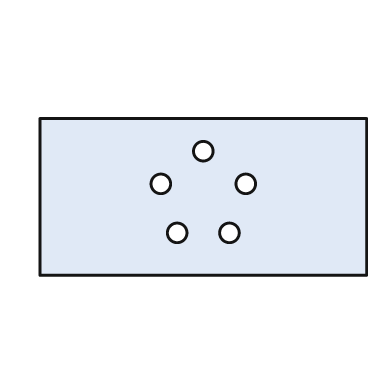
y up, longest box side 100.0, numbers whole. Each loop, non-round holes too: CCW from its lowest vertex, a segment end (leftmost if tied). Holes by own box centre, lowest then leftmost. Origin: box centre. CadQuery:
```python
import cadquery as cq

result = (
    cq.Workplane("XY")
    .moveTo(-50.0, -24.0)
    .lineTo(50.0, -24.0)
    .lineTo(50.0, 24.0)
    .lineTo(-50.0, 24.0)
    .close()
    .moveTo(-8.0, -11.0)
    .circle(3.0)
    .moveTo(8.0, -11.0)
    .circle(3.0)
    .moveTo(-13.0, 4.0)
    .circle(3.0)
    .moveTo(13.0, 4.0)
    .circle(3.0)
    .moveTo(0.0, 14.0)
    .circle(3.0)
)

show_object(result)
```